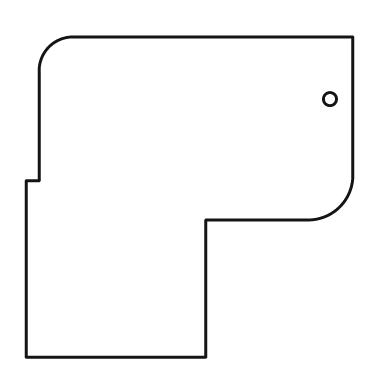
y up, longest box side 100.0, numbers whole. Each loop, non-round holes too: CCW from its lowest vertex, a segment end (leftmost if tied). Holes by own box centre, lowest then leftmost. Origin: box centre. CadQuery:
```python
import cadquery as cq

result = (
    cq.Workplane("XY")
    .moveTo(-50.0, -49.0)
    .lineTo(5.0, -49.0)
    .lineTo(5.0, -7.0)
    .lineTo(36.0, -7.0)
    .threePointArc((46.0, -3.0), (50.0, 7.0))
    .lineTo(50.0, 49.0)
    .lineTo(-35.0, 49.0)
    .threePointArc((-43.0, 46.0), (-46.0, 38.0))
    .lineTo(-46.0, 5.0)
    .lineTo(-50.0, 5.0)
    .close()
    .moveTo(43.0, 30.0)
    .circle(2.0)
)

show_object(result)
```